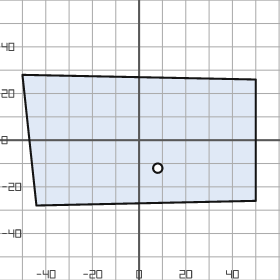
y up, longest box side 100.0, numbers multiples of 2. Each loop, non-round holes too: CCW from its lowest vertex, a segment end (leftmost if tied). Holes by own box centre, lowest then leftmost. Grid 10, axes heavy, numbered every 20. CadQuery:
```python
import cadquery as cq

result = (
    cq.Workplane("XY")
    .moveTo(-44.0, -28.0)
    .lineTo(50.0, -26.0)
    .lineTo(50.0, 26.0)
    .lineTo(-50.0, 28.0)
    .close()
    .moveTo(8.0, -12.0)
    .circle(2.0)
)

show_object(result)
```